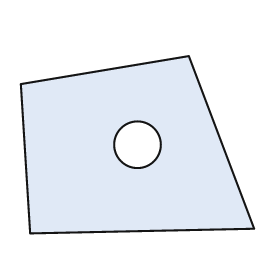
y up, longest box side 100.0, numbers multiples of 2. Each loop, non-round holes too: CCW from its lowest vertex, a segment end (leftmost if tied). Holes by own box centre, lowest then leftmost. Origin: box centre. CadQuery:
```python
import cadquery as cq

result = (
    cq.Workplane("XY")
    .moveTo(-46.0, -38.0)
    .lineTo(50.0, -36.0)
    .lineTo(22.0, 38.0)
    .lineTo(-50.0, 26.0)
    .close()
    .moveTo(0.0, 0.0)
    .circle(10.0)
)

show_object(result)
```